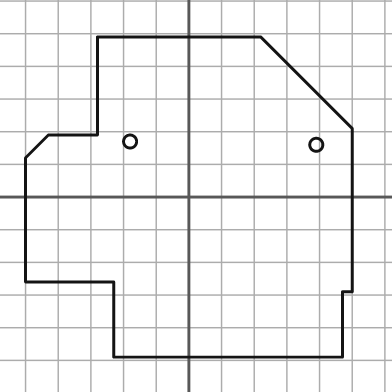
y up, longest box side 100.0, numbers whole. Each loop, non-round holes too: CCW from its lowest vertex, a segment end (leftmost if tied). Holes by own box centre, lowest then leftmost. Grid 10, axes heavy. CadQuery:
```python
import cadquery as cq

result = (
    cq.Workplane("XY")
    .moveTo(-23.0, -49.0)
    .lineTo(47.0, -49.0)
    .lineTo(47.0, -29.0)
    .lineTo(50.0, -29.0)
    .lineTo(50.0, 21.0)
    .lineTo(22.0, 49.0)
    .lineTo(-28.0, 49.0)
    .lineTo(-28.0, 19.0)
    .lineTo(-43.0, 19.0)
    .lineTo(-50.0, 12.0)
    .lineTo(-50.0, -26.0)
    .lineTo(-23.0, -26.0)
    .close()
    .moveTo(39.0, 16.0)
    .circle(2.0)
    .moveTo(-18.0, 17.0)
    .circle(2.0)
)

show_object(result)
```